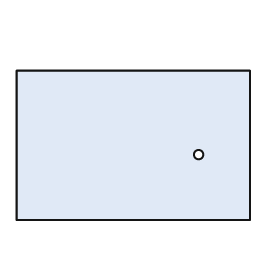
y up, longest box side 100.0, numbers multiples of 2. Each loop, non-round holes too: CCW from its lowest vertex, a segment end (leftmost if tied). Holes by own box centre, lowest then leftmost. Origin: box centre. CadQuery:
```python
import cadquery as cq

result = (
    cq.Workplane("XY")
    .moveTo(-50.0, -32.0)
    .lineTo(50.0, -32.0)
    .lineTo(50.0, 32.0)
    .lineTo(-50.0, 32.0)
    .close()
    .moveTo(28.0, -4.0)
    .circle(2.0)
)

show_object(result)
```